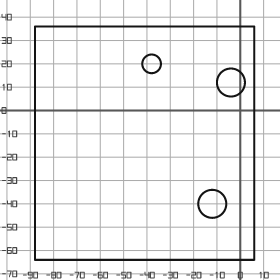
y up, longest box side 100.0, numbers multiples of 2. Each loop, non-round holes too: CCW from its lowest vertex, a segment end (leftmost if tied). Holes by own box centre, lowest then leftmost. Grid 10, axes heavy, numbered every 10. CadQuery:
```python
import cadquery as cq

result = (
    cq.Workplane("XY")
    .moveTo(-88.0, -64.0)
    .lineTo(6.0, -64.0)
    .lineTo(6.0, 36.0)
    .lineTo(-88.0, 36.0)
    .close()
    .moveTo(-12.0, -40.0)
    .circle(6.0)
    .moveTo(-4.0, 12.0)
    .circle(6.0)
    .moveTo(-38.0, 20.0)
    .circle(4.0)
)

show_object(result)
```